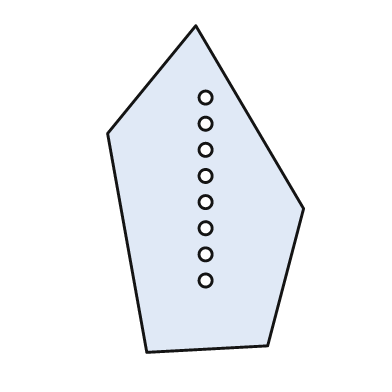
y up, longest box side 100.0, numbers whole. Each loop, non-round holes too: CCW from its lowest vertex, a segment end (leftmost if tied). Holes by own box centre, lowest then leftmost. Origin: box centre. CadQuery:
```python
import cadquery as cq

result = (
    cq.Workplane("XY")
    .moveTo(-18.0, -50.0)
    .lineTo(19.0, -48.0)
    .lineTo(30.0, -6.0)
    .lineTo(-3.0, 50.0)
    .lineTo(-30.0, 17.0)
    .close()
    .moveTo(0.0, -28.0)
    .circle(2.0)
    .moveTo(0.0, -20.0)
    .circle(2.0)
    .moveTo(0.0, -12.0)
    .circle(2.0)
    .moveTo(0.0, -4.0)
    .circle(2.0)
    .moveTo(0.0, 4.0)
    .circle(2.0)
    .moveTo(0.0, 12.0)
    .circle(2.0)
    .moveTo(0.0, 20.0)
    .circle(2.0)
    .moveTo(0.0, 28.0)
    .circle(2.0)
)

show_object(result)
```